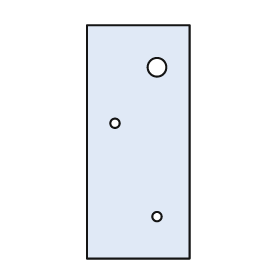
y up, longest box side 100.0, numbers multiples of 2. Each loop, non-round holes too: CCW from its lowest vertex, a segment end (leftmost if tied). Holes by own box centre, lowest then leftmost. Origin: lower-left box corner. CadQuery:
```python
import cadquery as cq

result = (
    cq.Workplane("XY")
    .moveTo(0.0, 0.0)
    .lineTo(44.0, 0.0)
    .lineTo(44.0, 100.0)
    .lineTo(0.0, 100.0)
    .close()
    .moveTo(30.0, 18.0)
    .circle(2.0)
    .moveTo(12.0, 58.0)
    .circle(2.0)
    .moveTo(30.0, 82.0)
    .circle(4.0)
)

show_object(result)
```